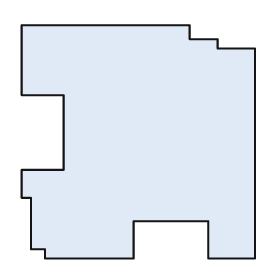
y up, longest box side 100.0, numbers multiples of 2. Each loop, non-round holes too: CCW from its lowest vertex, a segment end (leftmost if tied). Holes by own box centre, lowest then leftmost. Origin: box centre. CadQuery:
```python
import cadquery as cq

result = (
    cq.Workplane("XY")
    .moveTo(-40.0, -50.0)
    .lineTo(-2.0, -50.0)
    .lineTo(-2.0, -34.0)
    .lineTo(30.0, -34.0)
    .lineTo(30.0, -50.0)
    .lineTo(50.0, -50.0)
    .lineTo(50.0, 40.0)
    .lineTo(34.0, 40.0)
    .lineTo(34.0, 44.0)
    .lineTo(22.0, 44.0)
    .lineTo(22.0, 50.0)
    .lineTo(-50.0, 50.0)
    .lineTo(-50.0, 20.0)
    .lineTo(-32.0, 20.0)
    .lineTo(-32.0, -12.0)
    .lineTo(-50.0, -12.0)
    .lineTo(-50.0, -24.0)
    .lineTo(-46.0, -24.0)
    .lineTo(-46.0, -46.0)
    .lineTo(-40.0, -46.0)
    .close()
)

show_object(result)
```